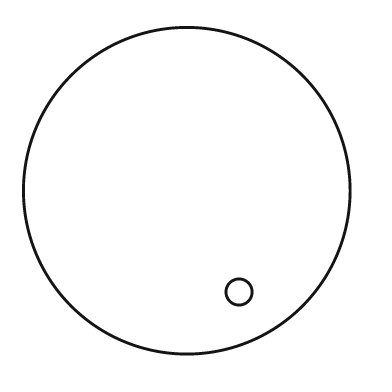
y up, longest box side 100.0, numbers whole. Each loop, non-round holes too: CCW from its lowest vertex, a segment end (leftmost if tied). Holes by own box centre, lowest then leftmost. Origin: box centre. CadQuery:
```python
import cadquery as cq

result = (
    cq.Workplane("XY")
    .moveTo(0.0, 0.0)
    .circle(50.0)
    .moveTo(16.0, -31.0)
    .circle(4.0)
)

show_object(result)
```